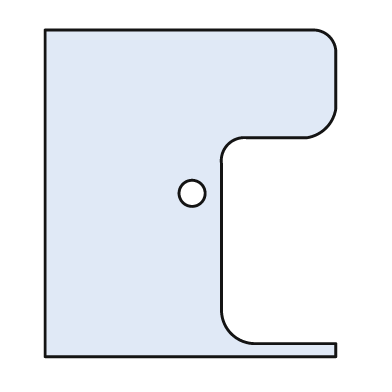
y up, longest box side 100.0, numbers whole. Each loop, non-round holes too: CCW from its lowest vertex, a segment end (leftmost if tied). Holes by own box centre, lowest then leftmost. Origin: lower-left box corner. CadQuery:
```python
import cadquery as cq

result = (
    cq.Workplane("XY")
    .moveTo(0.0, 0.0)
    .lineTo(89.0, 0.0)
    .lineTo(89.0, 4.0)
    .lineTo(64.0, 4.0)
    .threePointArc((57.0, 7.0), (54.0, 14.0))
    .lineTo(54.0, 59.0)
    .threePointArc((56.0, 65.0), (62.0, 67.0))
    .lineTo(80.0, 67.0)
    .threePointArc((86.0, 70.0), (89.0, 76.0))
    .lineTo(89.0, 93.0)
    .threePointArc((87.0, 98.0), (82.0, 100.0))
    .lineTo(0.0, 100.0)
    .close()
    .moveTo(45.0, 50.0)
    .circle(4.0)
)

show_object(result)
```